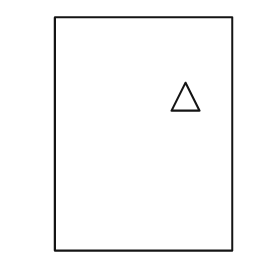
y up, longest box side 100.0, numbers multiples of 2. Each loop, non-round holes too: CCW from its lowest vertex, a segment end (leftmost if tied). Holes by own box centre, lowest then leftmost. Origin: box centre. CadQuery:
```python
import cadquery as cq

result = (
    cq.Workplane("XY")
    .moveTo(-38.0, -50.0)
    .lineTo(38.0, -50.0)
    .lineTo(38.0, 50.0)
    .lineTo(-38.0, 50.0)
    .close()
    .moveTo(12.0, 10.0)
    .lineTo(24.0, 10.0)
    .lineTo(18.0, 22.0)
    .close()
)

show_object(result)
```